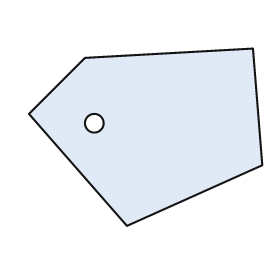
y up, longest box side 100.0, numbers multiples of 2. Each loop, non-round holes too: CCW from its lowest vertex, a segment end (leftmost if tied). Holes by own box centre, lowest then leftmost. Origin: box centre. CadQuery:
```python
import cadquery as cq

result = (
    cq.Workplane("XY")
    .moveTo(-8.0, -38.0)
    .lineTo(50.0, -12.0)
    .lineTo(46.0, 38.0)
    .lineTo(-26.0, 34.0)
    .lineTo(-50.0, 10.0)
    .close()
    .moveTo(-22.0, 6.0)
    .circle(4.0)
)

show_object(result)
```